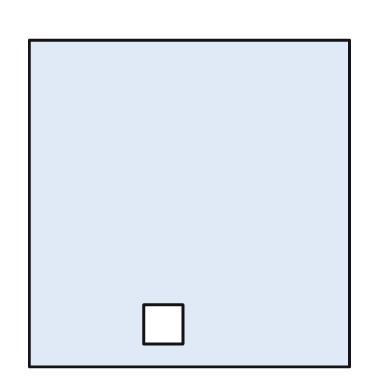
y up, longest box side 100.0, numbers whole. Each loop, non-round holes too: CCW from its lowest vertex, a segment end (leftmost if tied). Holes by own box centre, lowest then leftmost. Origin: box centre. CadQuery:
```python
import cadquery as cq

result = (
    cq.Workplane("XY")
    .moveTo(-49.0, -50.0)
    .lineTo(49.0, -50.0)
    .lineTo(49.0, 50.0)
    .lineTo(-49.0, 50.0)
    .close()
    .moveTo(-14.0, -43.0)
    .lineTo(-2.0, -43.0)
    .lineTo(-2.0, -31.0)
    .lineTo(-14.0, -31.0)
    .close()
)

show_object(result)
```